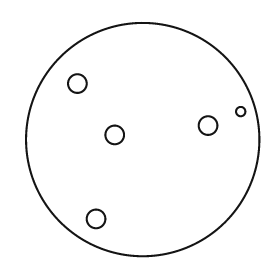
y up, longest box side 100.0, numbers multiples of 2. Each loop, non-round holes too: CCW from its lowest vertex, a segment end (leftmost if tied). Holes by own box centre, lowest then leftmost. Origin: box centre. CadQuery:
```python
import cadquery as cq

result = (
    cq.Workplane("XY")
    .moveTo(0.0, 0.0)
    .circle(50.0)
    .moveTo(-20.0, -34.0)
    .circle(4.0)
    .moveTo(-12.0, 2.0)
    .circle(4.0)
    .moveTo(28.0, 6.0)
    .circle(4.0)
    .moveTo(42.0, 12.0)
    .circle(2.0)
    .moveTo(-28.0, 24.0)
    .circle(4.0)
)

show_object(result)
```